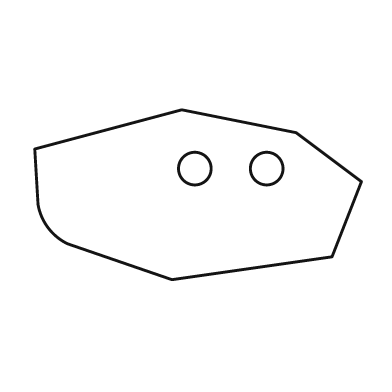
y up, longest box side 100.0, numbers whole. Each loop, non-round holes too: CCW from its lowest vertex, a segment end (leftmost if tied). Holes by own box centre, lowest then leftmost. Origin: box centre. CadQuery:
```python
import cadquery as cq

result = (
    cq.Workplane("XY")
    .moveTo(-8.0, -26.0)
    .lineTo(41.0, -19.0)
    .lineTo(50.0, 4.0)
    .lineTo(30.0, 19.0)
    .lineTo(-5.0, 26.0)
    .lineTo(-50.0, 14.0)
    .lineTo(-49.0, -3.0)
    .threePointArc((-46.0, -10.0), (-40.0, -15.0))
    .close()
    .moveTo(-1.0, 8.0)
    .circle(5.0)
    .moveTo(21.0, 8.0)
    .circle(5.0)
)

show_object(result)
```